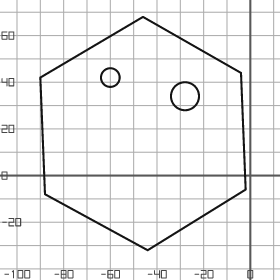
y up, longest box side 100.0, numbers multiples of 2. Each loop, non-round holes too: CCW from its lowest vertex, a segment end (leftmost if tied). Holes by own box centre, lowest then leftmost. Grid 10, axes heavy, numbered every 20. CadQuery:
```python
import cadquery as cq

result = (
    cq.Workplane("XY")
    .moveTo(-44.0, -32.0)
    .lineTo(-2.0, -6.0)
    .lineTo(-4.0, 44.0)
    .lineTo(-46.0, 68.0)
    .lineTo(-90.0, 42.0)
    .lineTo(-88.0, -8.0)
    .close()
    .moveTo(-28.0, 34.0)
    .circle(6.0)
    .moveTo(-60.0, 42.0)
    .circle(4.0)
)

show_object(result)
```